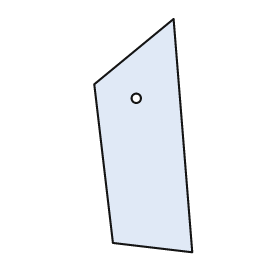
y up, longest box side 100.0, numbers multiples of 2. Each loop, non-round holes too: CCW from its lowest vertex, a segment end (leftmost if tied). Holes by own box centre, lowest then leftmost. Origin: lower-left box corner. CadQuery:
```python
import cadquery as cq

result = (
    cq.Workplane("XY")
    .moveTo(42.0, 0.0)
    .lineTo(34.0, 100.0)
    .lineTo(0.0, 72.0)
    .lineTo(8.0, 4.0)
    .close()
    .moveTo(18.0, 66.0)
    .circle(2.0)
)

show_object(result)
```